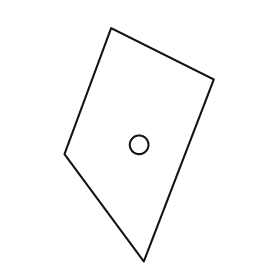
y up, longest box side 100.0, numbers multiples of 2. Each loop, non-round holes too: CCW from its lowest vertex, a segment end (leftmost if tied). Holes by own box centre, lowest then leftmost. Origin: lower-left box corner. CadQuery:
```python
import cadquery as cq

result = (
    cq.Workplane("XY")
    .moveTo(34.0, 0.0)
    .lineTo(64.0, 78.0)
    .lineTo(20.0, 100.0)
    .lineTo(0.0, 46.0)
    .close()
    .moveTo(32.0, 50.0)
    .circle(4.0)
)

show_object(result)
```